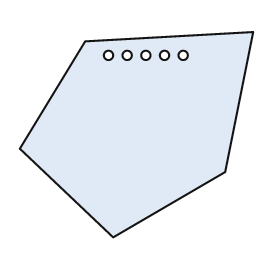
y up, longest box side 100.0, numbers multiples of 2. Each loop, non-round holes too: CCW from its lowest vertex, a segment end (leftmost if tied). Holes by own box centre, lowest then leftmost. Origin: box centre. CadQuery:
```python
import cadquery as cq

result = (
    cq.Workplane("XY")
    .moveTo(-10.0, -44.0)
    .lineTo(38.0, -16.0)
    .lineTo(50.0, 44.0)
    .lineTo(-22.0, 40.0)
    .lineTo(-50.0, -6.0)
    .close()
    .moveTo(-12.0, 34.0)
    .circle(2.0)
    .moveTo(-4.0, 34.0)
    .circle(2.0)
    .moveTo(4.0, 34.0)
    .circle(2.0)
    .moveTo(12.0, 34.0)
    .circle(2.0)
    .moveTo(20.0, 34.0)
    .circle(2.0)
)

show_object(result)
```